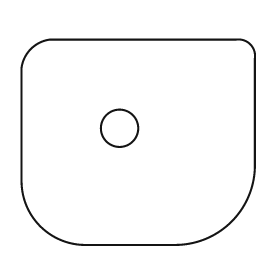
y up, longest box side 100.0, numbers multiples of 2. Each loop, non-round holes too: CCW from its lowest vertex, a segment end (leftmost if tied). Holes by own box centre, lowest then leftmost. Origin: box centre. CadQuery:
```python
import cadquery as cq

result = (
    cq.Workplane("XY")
    .moveTo(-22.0, -44.0)
    .lineTo(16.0, -44.0)
    .threePointArc((40.0, -34.0), (50.0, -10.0))
    .lineTo(50.0, 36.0)
    .threePointArc((48.0, 42.0), (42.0, 44.0))
    .lineTo(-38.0, 44.0)
    .threePointArc((-46.0, 40.0), (-50.0, 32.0))
    .lineTo(-50.0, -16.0)
    .threePointArc((-42.0, -36.0), (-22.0, -44.0))
    .close()
    .moveTo(-8.0, 6.0)
    .circle(8.0)
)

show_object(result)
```